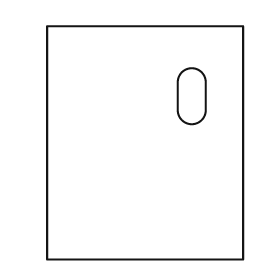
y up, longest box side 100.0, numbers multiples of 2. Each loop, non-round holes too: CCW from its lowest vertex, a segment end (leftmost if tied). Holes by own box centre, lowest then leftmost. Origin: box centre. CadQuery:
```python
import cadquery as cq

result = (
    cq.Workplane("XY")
    .moveTo(-42.0, -50.0)
    .lineTo(42.0, -50.0)
    .lineTo(42.0, 50.0)
    .lineTo(-42.0, 50.0)
    .close()
    .moveTo(14.0, 14.0)
    .threePointArc((20.0, 8.0), (26.0, 14.0))
    .lineTo(26.0, 26.0)
    .threePointArc((20.0, 32.0), (14.0, 26.0))
    .close()
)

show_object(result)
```